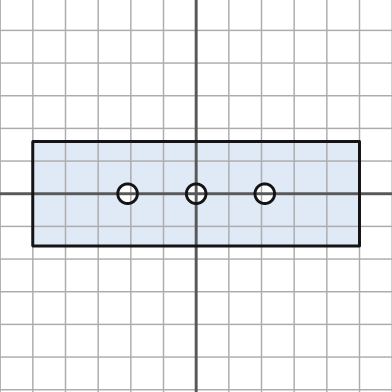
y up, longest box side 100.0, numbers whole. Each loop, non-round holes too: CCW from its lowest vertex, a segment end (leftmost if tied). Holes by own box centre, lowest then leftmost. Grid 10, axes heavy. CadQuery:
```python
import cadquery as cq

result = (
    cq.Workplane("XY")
    .moveTo(-50.0, -16.0)
    .lineTo(50.0, -16.0)
    .lineTo(50.0, 16.0)
    .lineTo(-50.0, 16.0)
    .close()
    .moveTo(-21.0, 0.0)
    .circle(3.0)
    .moveTo(0.0, 0.0)
    .circle(3.0)
    .moveTo(21.0, 0.0)
    .circle(3.0)
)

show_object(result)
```